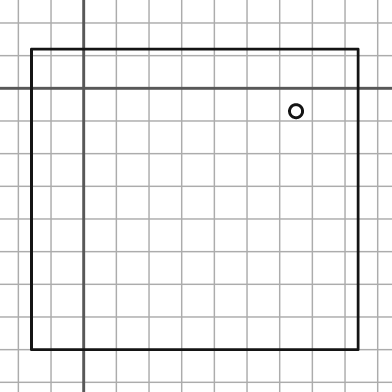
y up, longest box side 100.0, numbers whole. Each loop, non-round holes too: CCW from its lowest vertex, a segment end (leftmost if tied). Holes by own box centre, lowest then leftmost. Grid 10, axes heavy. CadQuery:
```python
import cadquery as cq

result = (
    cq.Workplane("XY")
    .moveTo(-16.0, -80.0)
    .lineTo(84.0, -80.0)
    .lineTo(84.0, 12.0)
    .lineTo(-16.0, 12.0)
    .close()
    .moveTo(65.0, -7.0)
    .circle(2.0)
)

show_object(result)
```